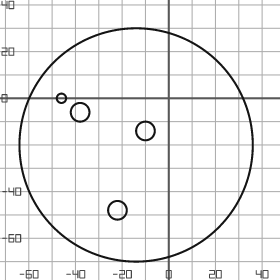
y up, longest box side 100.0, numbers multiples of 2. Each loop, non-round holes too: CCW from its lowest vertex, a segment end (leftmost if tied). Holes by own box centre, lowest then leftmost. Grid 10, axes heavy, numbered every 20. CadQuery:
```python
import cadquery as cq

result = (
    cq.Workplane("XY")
    .moveTo(-14.0, -20.0)
    .circle(50.0)
    .moveTo(-22.0, -48.0)
    .circle(4.0)
    .moveTo(-10.0, -14.0)
    .circle(4.0)
    .moveTo(-38.0, -6.0)
    .circle(4.0)
    .moveTo(-46.0, 0.0)
    .circle(2.0)
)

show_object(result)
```